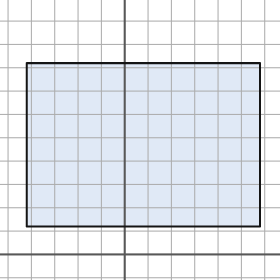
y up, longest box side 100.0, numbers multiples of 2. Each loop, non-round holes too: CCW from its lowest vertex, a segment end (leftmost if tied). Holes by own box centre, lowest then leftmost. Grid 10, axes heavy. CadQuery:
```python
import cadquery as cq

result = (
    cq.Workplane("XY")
    .moveTo(-42.0, 12.0)
    .lineTo(58.0, 12.0)
    .lineTo(58.0, 82.0)
    .lineTo(-42.0, 82.0)
    .close()
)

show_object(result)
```